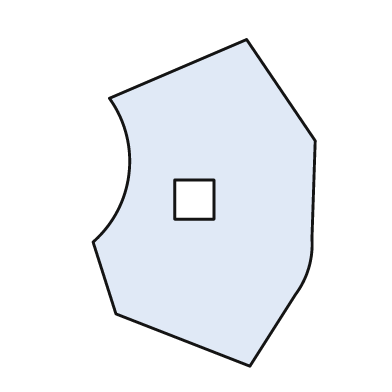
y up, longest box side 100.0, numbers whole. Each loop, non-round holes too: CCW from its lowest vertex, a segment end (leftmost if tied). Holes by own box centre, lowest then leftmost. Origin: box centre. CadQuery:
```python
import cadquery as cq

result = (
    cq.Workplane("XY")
    .moveTo(14.0, -50.0)
    .lineTo(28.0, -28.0)
    .threePointArc((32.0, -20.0), (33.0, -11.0))
    .lineTo(34.0, 19.0)
    .lineTo(13.0, 50.0)
    .lineTo(-29.0, 32.0)
    .threePointArc((-23.0, 9.0), (-34.0, -12.0))
    .lineTo(-27.0, -34.0)
    .close()
    .moveTo(-9.0, -5.0)
    .lineTo(3.0, -5.0)
    .lineTo(3.0, 7.0)
    .lineTo(-9.0, 7.0)
    .close()
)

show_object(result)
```